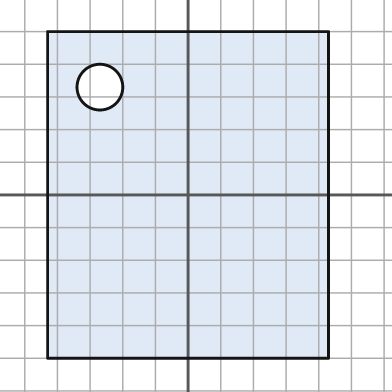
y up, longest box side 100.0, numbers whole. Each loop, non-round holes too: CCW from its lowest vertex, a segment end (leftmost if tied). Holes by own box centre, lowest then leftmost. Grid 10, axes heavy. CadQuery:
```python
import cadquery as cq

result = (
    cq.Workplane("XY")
    .moveTo(-43.0, -50.0)
    .lineTo(43.0, -50.0)
    .lineTo(43.0, 50.0)
    .lineTo(-43.0, 50.0)
    .close()
    .moveTo(-27.0, 33.0)
    .circle(7.0)
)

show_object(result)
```